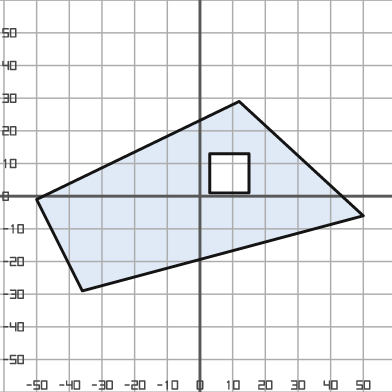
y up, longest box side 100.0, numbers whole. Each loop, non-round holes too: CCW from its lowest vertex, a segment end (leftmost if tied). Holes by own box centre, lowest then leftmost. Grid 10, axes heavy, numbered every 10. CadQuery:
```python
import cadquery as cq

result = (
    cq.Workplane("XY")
    .moveTo(-36.0, -29.0)
    .lineTo(50.0, -6.0)
    .lineTo(12.0, 29.0)
    .lineTo(-50.0, -1.0)
    .close()
    .moveTo(3.0, 1.0)
    .lineTo(15.0, 1.0)
    .lineTo(15.0, 13.0)
    .lineTo(3.0, 13.0)
    .close()
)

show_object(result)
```